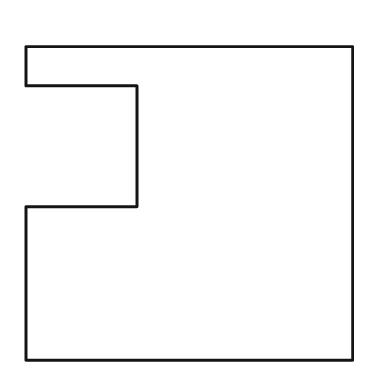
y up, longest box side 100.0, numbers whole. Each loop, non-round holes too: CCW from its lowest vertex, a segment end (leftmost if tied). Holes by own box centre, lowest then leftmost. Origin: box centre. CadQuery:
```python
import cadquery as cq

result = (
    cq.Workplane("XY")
    .moveTo(-50.0, -48.0)
    .lineTo(50.0, -48.0)
    .lineTo(50.0, 48.0)
    .lineTo(-50.0, 48.0)
    .lineTo(-50.0, 36.0)
    .lineTo(-16.0, 36.0)
    .lineTo(-16.0, -1.0)
    .lineTo(-50.0, -1.0)
    .close()
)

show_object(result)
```